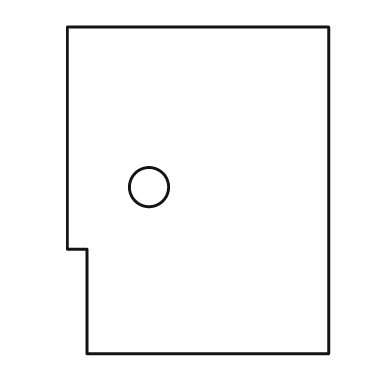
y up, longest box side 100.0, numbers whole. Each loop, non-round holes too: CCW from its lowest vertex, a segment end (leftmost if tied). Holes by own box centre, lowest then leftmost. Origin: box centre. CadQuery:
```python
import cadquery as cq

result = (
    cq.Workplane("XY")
    .moveTo(-34.0, -50.0)
    .lineTo(40.0, -50.0)
    .lineTo(40.0, 50.0)
    .lineTo(-40.0, 50.0)
    .lineTo(-40.0, -18.0)
    .lineTo(-34.0, -18.0)
    .close()
    .moveTo(-15.0, 1.0)
    .circle(6.0)
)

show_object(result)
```